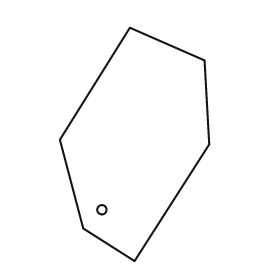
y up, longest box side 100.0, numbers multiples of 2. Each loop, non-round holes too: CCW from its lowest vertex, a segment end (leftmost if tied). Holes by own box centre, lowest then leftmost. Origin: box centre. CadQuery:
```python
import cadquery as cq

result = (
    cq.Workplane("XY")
    .moveTo(0.0, -50.0)
    .lineTo(32.0, 0.0)
    .lineTo(30.0, 36.0)
    .lineTo(-2.0, 50.0)
    .lineTo(-32.0, 2.0)
    .lineTo(-22.0, -36.0)
    .close()
    .moveTo(-14.0, -28.0)
    .circle(2.0)
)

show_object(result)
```